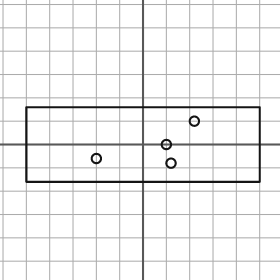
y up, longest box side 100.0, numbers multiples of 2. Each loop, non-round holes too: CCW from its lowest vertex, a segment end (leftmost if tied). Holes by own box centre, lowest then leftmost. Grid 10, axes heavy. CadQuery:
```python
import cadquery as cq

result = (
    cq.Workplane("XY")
    .moveTo(-50.0, -16.0)
    .lineTo(50.0, -16.0)
    .lineTo(50.0, 16.0)
    .lineTo(-50.0, 16.0)
    .close()
    .moveTo(12.0, -8.0)
    .circle(2.0)
    .moveTo(-20.0, -6.0)
    .circle(2.0)
    .moveTo(10.0, 0.0)
    .circle(2.0)
    .moveTo(22.0, 10.0)
    .circle(2.0)
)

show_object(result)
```